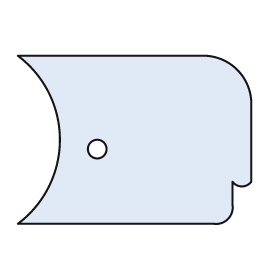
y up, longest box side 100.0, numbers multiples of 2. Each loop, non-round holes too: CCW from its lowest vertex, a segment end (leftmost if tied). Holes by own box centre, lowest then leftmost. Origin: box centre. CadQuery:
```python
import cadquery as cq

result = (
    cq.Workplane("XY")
    .moveTo(-50.0, -36.0)
    .lineTo(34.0, -36.0)
    .threePointArc((40.0, -34.0), (42.0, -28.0))
    .lineTo(42.0, -18.0)
    .threePointArc((46.0, -20.0), (50.0, -18.0))
    .lineTo(50.0, 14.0)
    .threePointArc((44.0, 30.0), (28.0, 36.0))
    .lineTo(-50.0, 36.0)
    .threePointArc((-32.0, 0.0), (-50.0, -36.0))
    .close()
    .moveTo(-16.0, -4.0)
    .circle(4.0)
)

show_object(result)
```